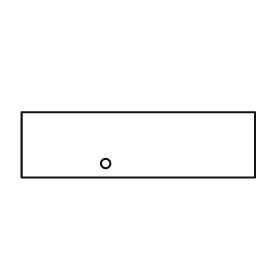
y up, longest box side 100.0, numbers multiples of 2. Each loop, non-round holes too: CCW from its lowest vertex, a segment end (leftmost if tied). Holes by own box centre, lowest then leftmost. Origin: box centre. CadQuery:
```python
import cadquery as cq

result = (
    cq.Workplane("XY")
    .moveTo(-50.0, -14.0)
    .lineTo(50.0, -14.0)
    .lineTo(50.0, 14.0)
    .lineTo(-50.0, 14.0)
    .close()
    .moveTo(-14.0, -8.0)
    .circle(2.0)
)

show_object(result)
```